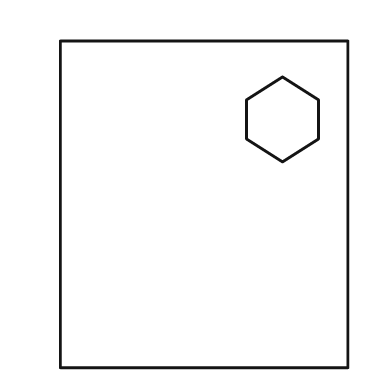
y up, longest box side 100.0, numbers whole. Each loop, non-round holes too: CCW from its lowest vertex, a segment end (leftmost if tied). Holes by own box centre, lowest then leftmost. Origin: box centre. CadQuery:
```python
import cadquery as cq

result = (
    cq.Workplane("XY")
    .moveTo(-44.0, -50.0)
    .lineTo(44.0, -50.0)
    .lineTo(44.0, 50.0)
    .lineTo(-44.0, 50.0)
    .close()
    .moveTo(24.0, 13.0)
    .lineTo(35.0, 20.0)
    .lineTo(35.0, 32.0)
    .lineTo(24.0, 39.0)
    .lineTo(13.0, 32.0)
    .lineTo(13.0, 20.0)
    .close()
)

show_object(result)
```